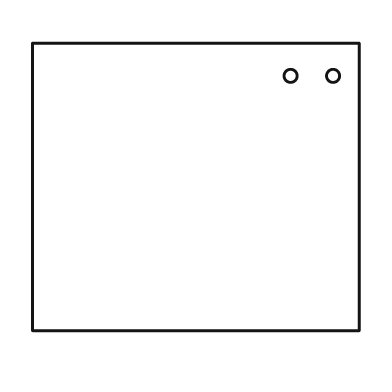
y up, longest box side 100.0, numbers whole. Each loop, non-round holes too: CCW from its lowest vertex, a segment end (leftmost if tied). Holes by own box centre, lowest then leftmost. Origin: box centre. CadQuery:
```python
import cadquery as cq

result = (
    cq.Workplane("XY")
    .moveTo(-50.0, -44.0)
    .lineTo(50.0, -44.0)
    .lineTo(50.0, 44.0)
    .lineTo(-50.0, 44.0)
    .close()
    .moveTo(29.0, 34.0)
    .circle(2.0)
    .moveTo(42.0, 34.0)
    .circle(2.0)
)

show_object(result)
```